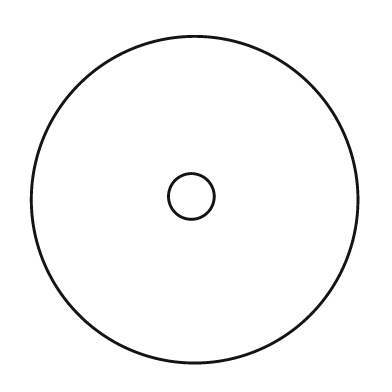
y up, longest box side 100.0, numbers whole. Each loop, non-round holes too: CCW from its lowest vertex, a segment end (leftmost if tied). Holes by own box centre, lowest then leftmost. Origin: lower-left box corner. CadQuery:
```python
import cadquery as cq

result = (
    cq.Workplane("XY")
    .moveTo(50.0, 50.0)
    .circle(50.0)
    .moveTo(49.0, 51.0)
    .circle(7.0)
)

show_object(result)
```